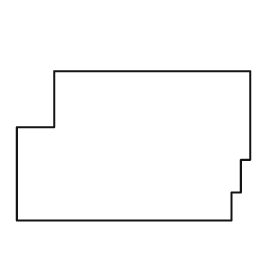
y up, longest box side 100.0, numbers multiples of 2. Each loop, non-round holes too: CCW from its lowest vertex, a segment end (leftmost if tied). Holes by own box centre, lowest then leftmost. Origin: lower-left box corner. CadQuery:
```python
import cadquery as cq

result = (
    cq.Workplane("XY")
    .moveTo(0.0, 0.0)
    .lineTo(92.0, 0.0)
    .lineTo(92.0, 12.0)
    .lineTo(96.0, 12.0)
    .lineTo(96.0, 26.0)
    .lineTo(100.0, 26.0)
    .lineTo(100.0, 64.0)
    .lineTo(16.0, 64.0)
    .lineTo(16.0, 40.0)
    .lineTo(0.0, 40.0)
    .close()
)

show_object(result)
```